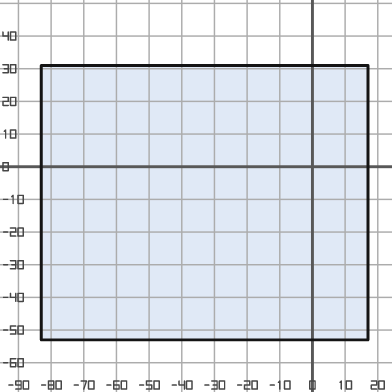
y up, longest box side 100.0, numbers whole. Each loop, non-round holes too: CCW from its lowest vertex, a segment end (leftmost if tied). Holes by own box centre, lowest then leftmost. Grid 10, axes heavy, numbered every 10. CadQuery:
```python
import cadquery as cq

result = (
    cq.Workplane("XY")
    .moveTo(-83.0, -53.0)
    .lineTo(17.0, -53.0)
    .lineTo(17.0, 31.0)
    .lineTo(-83.0, 31.0)
    .close()
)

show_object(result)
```